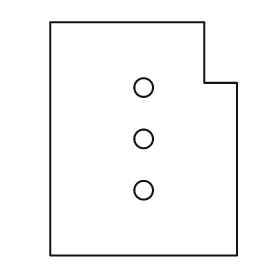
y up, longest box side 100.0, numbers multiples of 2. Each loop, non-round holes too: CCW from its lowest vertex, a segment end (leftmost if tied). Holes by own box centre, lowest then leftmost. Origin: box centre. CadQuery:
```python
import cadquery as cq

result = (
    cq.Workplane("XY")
    .moveTo(-40.0, -50.0)
    .lineTo(40.0, -50.0)
    .lineTo(40.0, 24.0)
    .lineTo(26.0, 24.0)
    .lineTo(26.0, 50.0)
    .lineTo(-40.0, 50.0)
    .close()
    .moveTo(0.0, -22.0)
    .circle(4.0)
    .moveTo(0.0, 0.0)
    .circle(4.0)
    .moveTo(0.0, 22.0)
    .circle(4.0)
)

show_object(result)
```